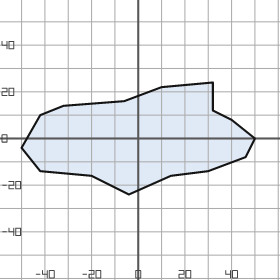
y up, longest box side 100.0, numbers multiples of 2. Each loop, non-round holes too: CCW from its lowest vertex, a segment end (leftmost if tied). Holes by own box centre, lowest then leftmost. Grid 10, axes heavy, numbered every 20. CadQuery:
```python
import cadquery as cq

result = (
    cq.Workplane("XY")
    .moveTo(-4.0, -24.0)
    .lineTo(14.0, -16.0)
    .lineTo(30.0, -14.0)
    .lineTo(46.0, -8.0)
    .lineTo(50.0, 0.0)
    .lineTo(40.0, 8.0)
    .lineTo(32.0, 12.0)
    .lineTo(32.0, 24.0)
    .lineTo(10.0, 22.0)
    .lineTo(-6.0, 16.0)
    .lineTo(-32.0, 14.0)
    .lineTo(-42.0, 10.0)
    .lineTo(-50.0, -4.0)
    .lineTo(-42.0, -14.0)
    .lineTo(-20.0, -16.0)
    .close()
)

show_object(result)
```